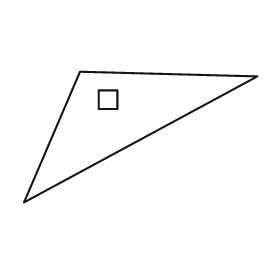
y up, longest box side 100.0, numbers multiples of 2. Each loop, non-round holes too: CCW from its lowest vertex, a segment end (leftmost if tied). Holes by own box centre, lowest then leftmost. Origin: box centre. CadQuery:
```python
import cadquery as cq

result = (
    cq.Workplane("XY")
    .moveTo(-50.0, -28.0)
    .lineTo(50.0, 26.0)
    .lineTo(-26.0, 28.0)
    .close()
    .moveTo(-18.0, 12.0)
    .lineTo(-10.0, 12.0)
    .lineTo(-10.0, 20.0)
    .lineTo(-18.0, 20.0)
    .close()
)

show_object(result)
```